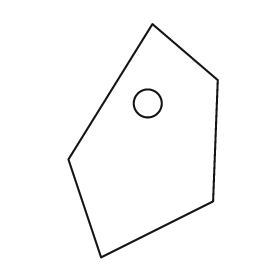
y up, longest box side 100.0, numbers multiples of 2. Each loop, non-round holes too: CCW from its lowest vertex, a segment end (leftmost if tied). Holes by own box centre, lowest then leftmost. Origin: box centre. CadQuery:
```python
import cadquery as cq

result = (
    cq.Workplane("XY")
    .moveTo(-18.0, -50.0)
    .lineTo(30.0, -26.0)
    .lineTo(32.0, 26.0)
    .lineTo(4.0, 50.0)
    .lineTo(-32.0, -8.0)
    .close()
    .moveTo(2.0, 16.0)
    .circle(6.0)
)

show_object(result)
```